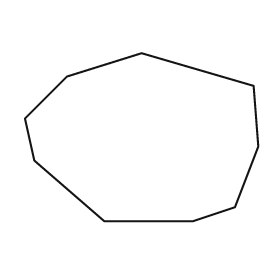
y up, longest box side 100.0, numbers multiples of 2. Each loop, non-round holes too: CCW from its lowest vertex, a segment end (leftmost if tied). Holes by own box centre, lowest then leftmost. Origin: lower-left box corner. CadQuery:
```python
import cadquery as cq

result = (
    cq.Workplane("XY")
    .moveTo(34.0, 0.0)
    .lineTo(72.0, 0.0)
    .lineTo(90.0, 6.0)
    .lineTo(100.0, 32.0)
    .lineTo(98.0, 58.0)
    .lineTo(50.0, 72.0)
    .lineTo(18.0, 62.0)
    .lineTo(0.0, 44.0)
    .lineTo(4.0, 26.0)
    .close()
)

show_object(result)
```